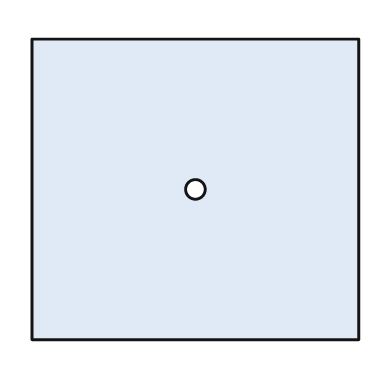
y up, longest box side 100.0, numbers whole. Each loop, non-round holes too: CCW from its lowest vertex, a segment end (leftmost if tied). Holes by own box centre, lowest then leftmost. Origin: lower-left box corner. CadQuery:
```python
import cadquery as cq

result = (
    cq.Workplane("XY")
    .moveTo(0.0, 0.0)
    .lineTo(100.0, 0.0)
    .lineTo(100.0, 92.0)
    .lineTo(0.0, 92.0)
    .close()
    .moveTo(50.0, 46.0)
    .circle(3.0)
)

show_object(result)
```